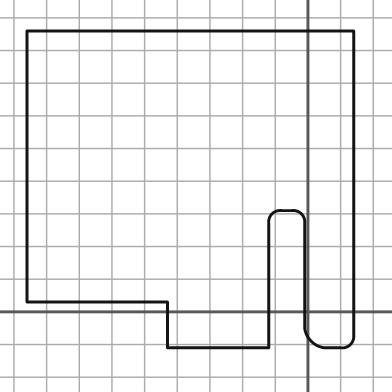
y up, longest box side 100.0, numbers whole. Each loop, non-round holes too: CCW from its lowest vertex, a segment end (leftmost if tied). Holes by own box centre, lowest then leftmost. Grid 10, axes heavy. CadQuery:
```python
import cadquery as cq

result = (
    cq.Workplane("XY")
    .moveTo(-43.0, -11.0)
    .lineTo(-12.0, -11.0)
    .lineTo(-12.0, 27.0)
    .threePointArc((-11.0, 30.0), (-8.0, 31.0))
    .lineTo(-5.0, 31.0)
    .threePointArc((-2.0, 30.0), (-1.0, 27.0))
    .lineTo(-1.0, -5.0)
    .threePointArc((1.0, -9.0), (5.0, -11.0))
    .lineTo(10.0, -11.0)
    .threePointArc((13.0, -10.0), (14.0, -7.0))
    .lineTo(14.0, 86.0)
    .lineTo(-86.0, 86.0)
    .lineTo(-86.0, 3.0)
    .lineTo(-43.0, 3.0)
    .close()
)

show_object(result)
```